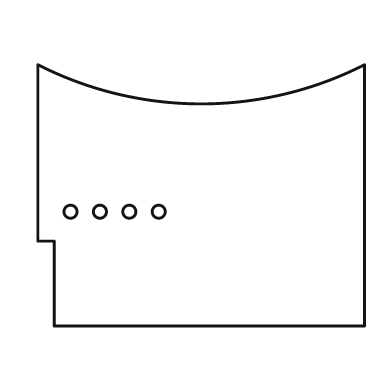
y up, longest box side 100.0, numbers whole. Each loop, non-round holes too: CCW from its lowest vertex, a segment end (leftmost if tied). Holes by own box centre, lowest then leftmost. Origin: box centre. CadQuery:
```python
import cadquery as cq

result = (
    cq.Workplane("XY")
    .moveTo(-45.0, -40.0)
    .lineTo(50.0, -40.0)
    .lineTo(50.0, 40.0)
    .threePointArc((0.0, 28.0), (-50.0, 40.0))
    .lineTo(-50.0, -14.0)
    .lineTo(-45.0, -14.0)
    .close()
    .moveTo(-40.0, -5.0)
    .circle(2.0)
    .moveTo(-31.0, -5.0)
    .circle(2.0)
    .moveTo(-22.0, -5.0)
    .circle(2.0)
    .moveTo(-13.0, -5.0)
    .circle(2.0)
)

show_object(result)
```